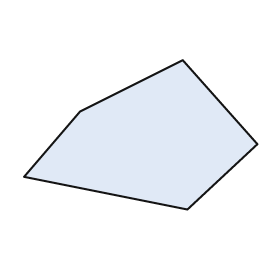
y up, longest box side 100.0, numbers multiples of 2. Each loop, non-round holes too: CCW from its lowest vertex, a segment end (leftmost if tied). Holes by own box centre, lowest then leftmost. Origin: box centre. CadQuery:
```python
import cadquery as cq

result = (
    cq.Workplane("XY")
    .moveTo(20.0, -32.0)
    .lineTo(50.0, -4.0)
    .lineTo(18.0, 32.0)
    .lineTo(-26.0, 10.0)
    .lineTo(-50.0, -18.0)
    .close()
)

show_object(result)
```